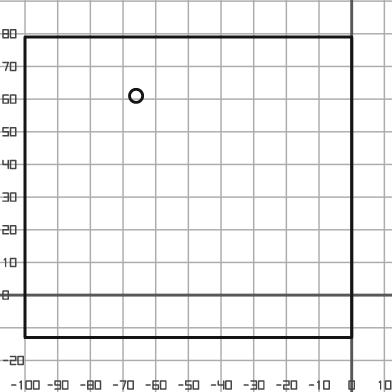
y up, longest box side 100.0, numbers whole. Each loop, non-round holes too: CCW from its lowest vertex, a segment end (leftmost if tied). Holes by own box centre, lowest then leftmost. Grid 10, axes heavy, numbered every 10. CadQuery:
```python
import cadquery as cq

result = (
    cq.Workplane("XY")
    .moveTo(-100.0, -13.0)
    .lineTo(0.0, -13.0)
    .lineTo(0.0, 79.0)
    .lineTo(-100.0, 79.0)
    .close()
    .moveTo(-66.0, 61.0)
    .circle(2.0)
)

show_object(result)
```